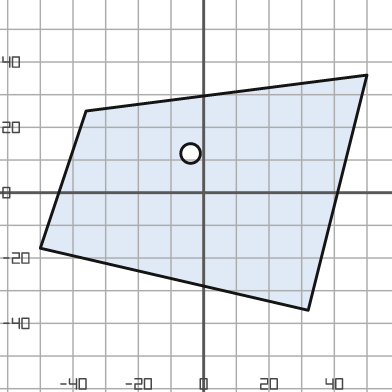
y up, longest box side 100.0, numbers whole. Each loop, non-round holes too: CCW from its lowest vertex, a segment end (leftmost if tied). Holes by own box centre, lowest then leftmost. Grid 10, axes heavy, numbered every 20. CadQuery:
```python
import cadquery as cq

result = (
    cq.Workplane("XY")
    .moveTo(32.0, -36.0)
    .lineTo(50.0, 36.0)
    .lineTo(-36.0, 25.0)
    .lineTo(-50.0, -17.0)
    .close()
    .moveTo(-4.0, 12.0)
    .circle(3.0)
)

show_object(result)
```